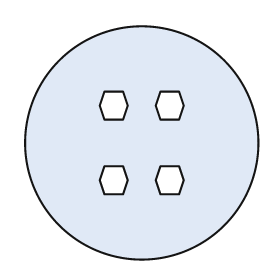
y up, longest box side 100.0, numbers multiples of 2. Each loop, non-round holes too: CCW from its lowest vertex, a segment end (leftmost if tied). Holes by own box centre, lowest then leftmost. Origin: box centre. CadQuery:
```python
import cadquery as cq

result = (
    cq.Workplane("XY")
    .moveTo(0.0, 0.0)
    .circle(50.0)
    .moveTo(-16.0, -22.0)
    .lineTo(-8.0, -22.0)
    .lineTo(-6.0, -16.0)
    .lineTo(-8.0, -10.0)
    .lineTo(-16.0, -10.0)
    .lineTo(-18.0, -16.0)
    .close()
    .moveTo(8.0, -22.0)
    .lineTo(16.0, -22.0)
    .lineTo(18.0, -16.0)
    .lineTo(16.0, -10.0)
    .lineTo(8.0, -10.0)
    .lineTo(6.0, -16.0)
    .close()
    .moveTo(-16.0, 10.0)
    .lineTo(-8.0, 10.0)
    .lineTo(-6.0, 16.0)
    .lineTo(-8.0, 22.0)
    .lineTo(-16.0, 22.0)
    .lineTo(-18.0, 16.0)
    .close()
    .moveTo(8.0, 10.0)
    .lineTo(16.0, 10.0)
    .lineTo(18.0, 16.0)
    .lineTo(16.0, 22.0)
    .lineTo(8.0, 22.0)
    .lineTo(6.0, 16.0)
    .close()
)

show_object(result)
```